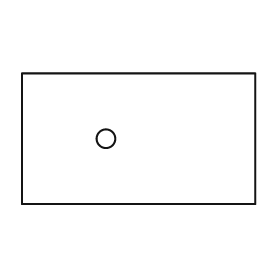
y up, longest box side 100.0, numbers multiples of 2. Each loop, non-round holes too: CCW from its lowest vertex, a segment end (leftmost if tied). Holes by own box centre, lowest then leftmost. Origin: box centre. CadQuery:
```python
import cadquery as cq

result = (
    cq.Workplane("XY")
    .moveTo(-50.0, -28.0)
    .lineTo(50.0, -28.0)
    .lineTo(50.0, 28.0)
    .lineTo(-50.0, 28.0)
    .close()
    .moveTo(-14.0, 0.0)
    .circle(4.0)
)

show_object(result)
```